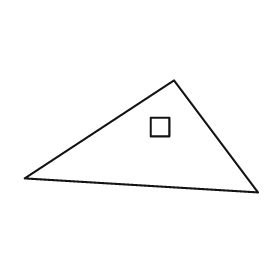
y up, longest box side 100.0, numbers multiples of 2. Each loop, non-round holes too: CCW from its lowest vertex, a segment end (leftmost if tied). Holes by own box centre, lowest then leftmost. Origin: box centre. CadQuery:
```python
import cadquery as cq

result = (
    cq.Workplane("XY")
    .moveTo(50.0, -24.0)
    .lineTo(14.0, 24.0)
    .lineTo(-50.0, -18.0)
    .close()
    .moveTo(4.0, 0.0)
    .lineTo(12.0, 0.0)
    .lineTo(12.0, 8.0)
    .lineTo(4.0, 8.0)
    .close()
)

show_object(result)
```